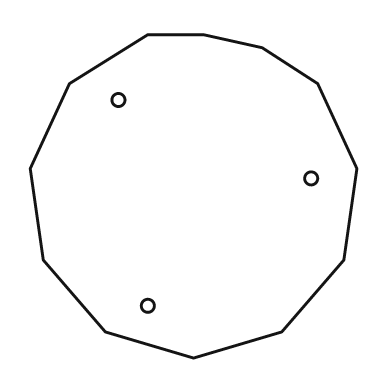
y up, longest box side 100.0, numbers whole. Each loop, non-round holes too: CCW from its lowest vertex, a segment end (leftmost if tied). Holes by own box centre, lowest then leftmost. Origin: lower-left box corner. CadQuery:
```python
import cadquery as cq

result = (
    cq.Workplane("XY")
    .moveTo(50.0, 0.0)
    .lineTo(77.0, 8.0)
    .lineTo(96.0, 30.0)
    .lineTo(100.0, 58.0)
    .lineTo(88.0, 84.0)
    .lineTo(71.0, 95.0)
    .lineTo(53.0, 99.0)
    .lineTo(36.0, 99.0)
    .lineTo(12.0, 84.0)
    .lineTo(0.0, 58.0)
    .lineTo(4.0, 30.0)
    .lineTo(23.0, 8.0)
    .close()
    .moveTo(36.0, 16.0)
    .circle(2.0)
    .moveTo(86.0, 55.0)
    .circle(2.0)
    .moveTo(27.0, 79.0)
    .circle(2.0)
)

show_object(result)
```